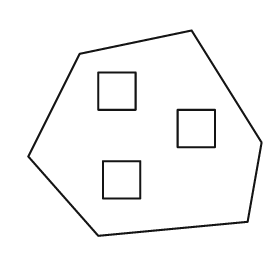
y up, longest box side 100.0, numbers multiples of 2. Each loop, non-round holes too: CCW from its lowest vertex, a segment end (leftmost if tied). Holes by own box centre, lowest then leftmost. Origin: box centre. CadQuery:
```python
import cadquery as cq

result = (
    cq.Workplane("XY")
    .moveTo(-20.0, -44.0)
    .lineTo(44.0, -38.0)
    .lineTo(50.0, -4.0)
    .lineTo(20.0, 44.0)
    .lineTo(-28.0, 34.0)
    .lineTo(-50.0, -10.0)
    .close()
    .moveTo(-18.0, -28.0)
    .lineTo(-2.0, -28.0)
    .lineTo(-2.0, -12.0)
    .lineTo(-18.0, -12.0)
    .close()
    .moveTo(14.0, -6.0)
    .lineTo(30.0, -6.0)
    .lineTo(30.0, 10.0)
    .lineTo(14.0, 10.0)
    .close()
    .moveTo(-20.0, 10.0)
    .lineTo(-4.0, 10.0)
    .lineTo(-4.0, 26.0)
    .lineTo(-20.0, 26.0)
    .close()
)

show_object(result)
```